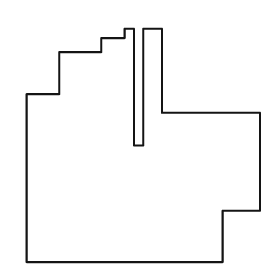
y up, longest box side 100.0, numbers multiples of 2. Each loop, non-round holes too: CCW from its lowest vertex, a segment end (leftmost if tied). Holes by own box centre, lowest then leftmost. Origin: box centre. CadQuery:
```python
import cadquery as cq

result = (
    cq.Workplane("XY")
    .moveTo(-50.0, -50.0)
    .lineTo(34.0, -50.0)
    .lineTo(34.0, -28.0)
    .lineTo(50.0, -28.0)
    .lineTo(50.0, 14.0)
    .lineTo(8.0, 14.0)
    .lineTo(8.0, 50.0)
    .lineTo(0.0, 50.0)
    .lineTo(0.0, 0.0)
    .lineTo(-4.0, 0.0)
    .lineTo(-4.0, 50.0)
    .lineTo(-8.0, 50.0)
    .lineTo(-8.0, 46.0)
    .lineTo(-18.0, 46.0)
    .lineTo(-18.0, 40.0)
    .lineTo(-36.0, 40.0)
    .lineTo(-36.0, 22.0)
    .lineTo(-50.0, 22.0)
    .close()
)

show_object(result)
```